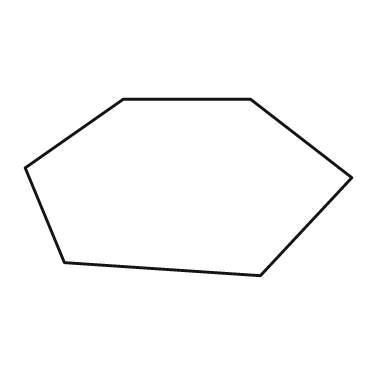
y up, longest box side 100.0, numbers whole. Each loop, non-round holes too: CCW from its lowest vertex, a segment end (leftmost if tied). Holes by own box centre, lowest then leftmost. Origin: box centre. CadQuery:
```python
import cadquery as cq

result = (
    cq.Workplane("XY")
    .moveTo(22.0, -27.0)
    .lineTo(50.0, 3.0)
    .lineTo(19.0, 27.0)
    .lineTo(-20.0, 27.0)
    .lineTo(-50.0, 6.0)
    .lineTo(-38.0, -23.0)
    .close()
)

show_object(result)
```